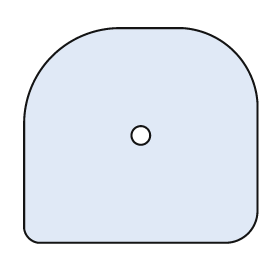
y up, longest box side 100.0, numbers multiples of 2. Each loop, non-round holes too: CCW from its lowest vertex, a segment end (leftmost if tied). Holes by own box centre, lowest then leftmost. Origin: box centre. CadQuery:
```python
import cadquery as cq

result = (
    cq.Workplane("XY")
    .moveTo(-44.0, -46.0)
    .lineTo(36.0, -46.0)
    .threePointArc((46.0, -42.0), (50.0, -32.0))
    .lineTo(50.0, 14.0)
    .threePointArc((40.0, 36.0), (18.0, 46.0))
    .lineTo(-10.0, 46.0)
    .threePointArc((-38.0, 34.0), (-50.0, 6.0))
    .lineTo(-50.0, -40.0)
    .threePointArc((-48.0, -44.0), (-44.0, -46.0))
    .close()
    .moveTo(0.0, 0.0)
    .circle(4.0)
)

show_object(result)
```